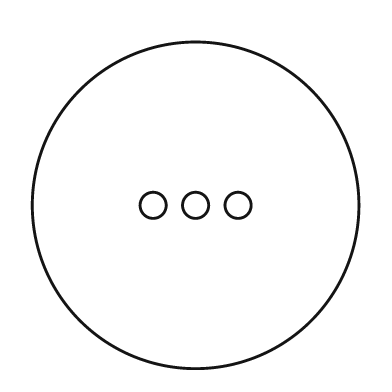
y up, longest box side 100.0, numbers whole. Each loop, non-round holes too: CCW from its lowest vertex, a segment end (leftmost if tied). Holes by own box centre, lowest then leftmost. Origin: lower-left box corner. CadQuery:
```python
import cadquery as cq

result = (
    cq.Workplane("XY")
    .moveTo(50.0, 50.0)
    .circle(50.0)
    .moveTo(37.0, 50.0)
    .circle(4.0)
    .moveTo(50.0, 50.0)
    .circle(4.0)
    .moveTo(63.0, 50.0)
    .circle(4.0)
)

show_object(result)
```